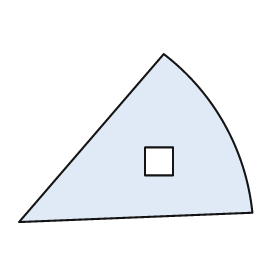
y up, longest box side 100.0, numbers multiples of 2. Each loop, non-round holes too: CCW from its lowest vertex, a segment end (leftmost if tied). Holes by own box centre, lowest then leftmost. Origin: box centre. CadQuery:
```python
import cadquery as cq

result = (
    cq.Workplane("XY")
    .moveTo(-50.0, -36.0)
    .lineTo(50.0, -32.0)
    .threePointArc((38.0, 6.0), (12.0, 36.0))
    .close()
    .moveTo(4.0, -16.0)
    .lineTo(16.0, -16.0)
    .lineTo(16.0, -4.0)
    .lineTo(4.0, -4.0)
    .close()
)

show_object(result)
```